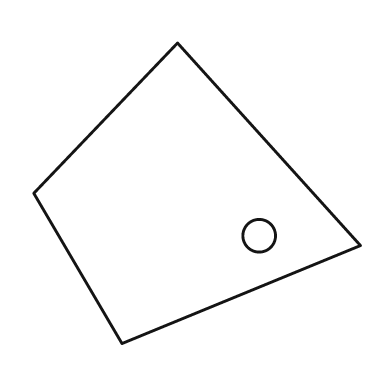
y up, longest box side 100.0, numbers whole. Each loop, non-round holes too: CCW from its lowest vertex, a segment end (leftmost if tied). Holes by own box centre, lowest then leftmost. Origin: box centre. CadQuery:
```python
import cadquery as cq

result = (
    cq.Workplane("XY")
    .moveTo(-23.0, -46.0)
    .lineTo(50.0, -16.0)
    .lineTo(-6.0, 46.0)
    .lineTo(-50.0, 0.0)
    .close()
    .moveTo(19.0, -13.0)
    .circle(5.0)
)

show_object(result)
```